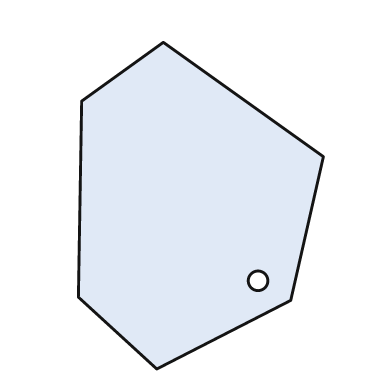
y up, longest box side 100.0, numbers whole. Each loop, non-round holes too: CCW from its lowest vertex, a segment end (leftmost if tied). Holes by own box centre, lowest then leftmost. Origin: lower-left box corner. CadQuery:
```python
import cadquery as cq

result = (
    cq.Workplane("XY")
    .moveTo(24.0, 0.0)
    .lineTo(65.0, 21.0)
    .lineTo(75.0, 65.0)
    .lineTo(26.0, 100.0)
    .lineTo(1.0, 82.0)
    .lineTo(0.0, 22.0)
    .close()
    .moveTo(55.0, 27.0)
    .circle(3.0)
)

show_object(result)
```